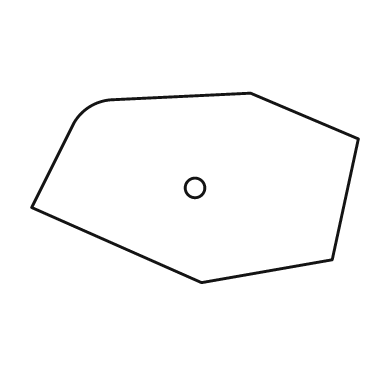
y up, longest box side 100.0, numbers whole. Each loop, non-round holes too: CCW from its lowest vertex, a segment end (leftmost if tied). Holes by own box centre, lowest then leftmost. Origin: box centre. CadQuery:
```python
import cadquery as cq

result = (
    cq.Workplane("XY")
    .moveTo(2.0, -29.0)
    .lineTo(42.0, -22.0)
    .lineTo(50.0, 15.0)
    .lineTo(17.0, 29.0)
    .lineTo(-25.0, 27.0)
    .threePointArc((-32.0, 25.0), (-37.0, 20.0))
    .lineTo(-50.0, -6.0)
    .close()
    .moveTo(0.0, 0.0)
    .circle(3.0)
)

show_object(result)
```